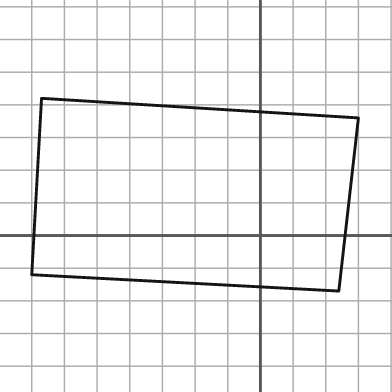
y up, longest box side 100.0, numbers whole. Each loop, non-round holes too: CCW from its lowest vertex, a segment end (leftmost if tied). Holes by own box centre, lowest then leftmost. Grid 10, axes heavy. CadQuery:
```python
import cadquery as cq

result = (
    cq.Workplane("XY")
    .moveTo(24.0, -17.0)
    .lineTo(30.0, 36.0)
    .lineTo(-67.0, 42.0)
    .lineTo(-70.0, -12.0)
    .close()
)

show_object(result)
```